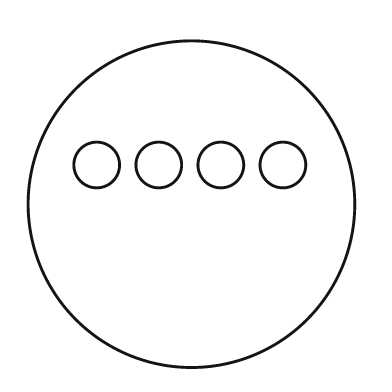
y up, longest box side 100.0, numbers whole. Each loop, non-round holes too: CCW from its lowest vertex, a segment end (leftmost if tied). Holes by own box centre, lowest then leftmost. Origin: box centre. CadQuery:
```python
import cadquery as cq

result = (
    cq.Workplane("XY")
    .moveTo(0.0, 0.0)
    .circle(50.0)
    .moveTo(-29.0, 12.0)
    .circle(7.0)
    .moveTo(-10.0, 12.0)
    .circle(7.0)
    .moveTo(9.0, 12.0)
    .circle(7.0)
    .moveTo(28.0, 12.0)
    .circle(7.0)
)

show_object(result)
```